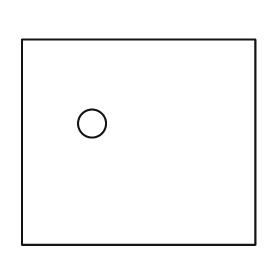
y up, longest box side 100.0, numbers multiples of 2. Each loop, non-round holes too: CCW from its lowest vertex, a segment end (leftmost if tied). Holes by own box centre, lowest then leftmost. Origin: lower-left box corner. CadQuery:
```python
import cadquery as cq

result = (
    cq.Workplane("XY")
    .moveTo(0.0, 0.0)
    .lineTo(100.0, 0.0)
    .lineTo(100.0, 88.0)
    .lineTo(0.0, 88.0)
    .close()
    .moveTo(30.0, 52.0)
    .circle(6.0)
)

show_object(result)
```